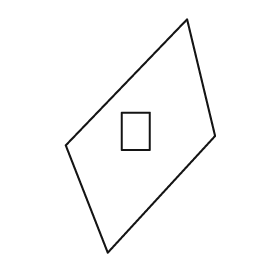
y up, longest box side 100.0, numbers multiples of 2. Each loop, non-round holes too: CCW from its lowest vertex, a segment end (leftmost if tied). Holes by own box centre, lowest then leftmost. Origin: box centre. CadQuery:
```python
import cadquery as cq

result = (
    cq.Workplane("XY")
    .moveTo(-14.0, -50.0)
    .lineTo(32.0, 0.0)
    .lineTo(20.0, 50.0)
    .lineTo(-32.0, -4.0)
    .close()
    .moveTo(-8.0, -6.0)
    .lineTo(4.0, -6.0)
    .lineTo(4.0, 10.0)
    .lineTo(-8.0, 10.0)
    .close()
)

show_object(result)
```